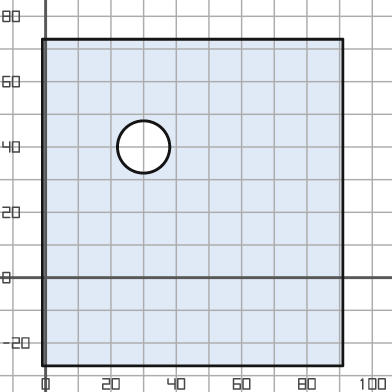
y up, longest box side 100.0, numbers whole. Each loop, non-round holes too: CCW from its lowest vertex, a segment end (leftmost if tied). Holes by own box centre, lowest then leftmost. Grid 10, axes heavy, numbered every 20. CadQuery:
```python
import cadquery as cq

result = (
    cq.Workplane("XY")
    .moveTo(-1.0, -27.0)
    .lineTo(91.0, -27.0)
    .lineTo(91.0, 73.0)
    .lineTo(-1.0, 73.0)
    .close()
    .moveTo(30.0, 40.0)
    .circle(8.0)
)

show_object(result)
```